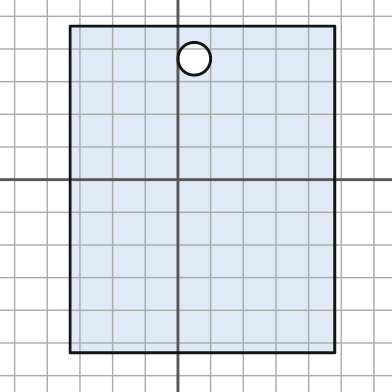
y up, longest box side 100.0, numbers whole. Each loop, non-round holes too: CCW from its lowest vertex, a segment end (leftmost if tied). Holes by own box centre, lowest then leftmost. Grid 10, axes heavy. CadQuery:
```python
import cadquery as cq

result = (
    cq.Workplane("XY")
    .moveTo(-33.0, -53.0)
    .lineTo(48.0, -53.0)
    .lineTo(48.0, 47.0)
    .lineTo(-33.0, 47.0)
    .close()
    .moveTo(5.0, 37.0)
    .circle(5.0)
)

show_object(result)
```